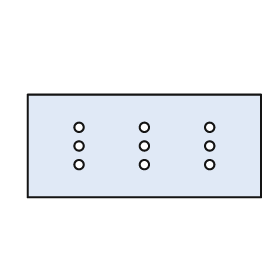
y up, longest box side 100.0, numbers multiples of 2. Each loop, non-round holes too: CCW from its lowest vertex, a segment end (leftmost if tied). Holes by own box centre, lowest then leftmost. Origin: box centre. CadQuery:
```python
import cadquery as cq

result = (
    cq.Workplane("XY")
    .moveTo(-50.0, -22.0)
    .lineTo(50.0, -22.0)
    .lineTo(50.0, 22.0)
    .lineTo(-50.0, 22.0)
    .close()
    .moveTo(-28.0, -8.0)
    .circle(2.0)
    .moveTo(0.0, -8.0)
    .circle(2.0)
    .moveTo(28.0, -8.0)
    .circle(2.0)
    .moveTo(-28.0, 0.0)
    .circle(2.0)
    .moveTo(0.0, 0.0)
    .circle(2.0)
    .moveTo(28.0, 0.0)
    .circle(2.0)
    .moveTo(-28.0, 8.0)
    .circle(2.0)
    .moveTo(0.0, 8.0)
    .circle(2.0)
    .moveTo(28.0, 8.0)
    .circle(2.0)
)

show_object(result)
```